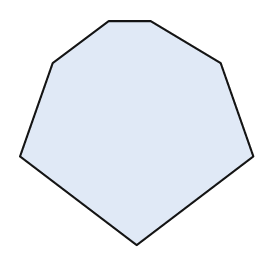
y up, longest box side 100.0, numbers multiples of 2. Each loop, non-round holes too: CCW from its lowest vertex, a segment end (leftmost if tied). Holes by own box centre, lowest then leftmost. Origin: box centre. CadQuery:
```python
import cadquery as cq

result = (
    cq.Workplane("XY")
    .moveTo(0.0, -48.0)
    .lineTo(50.0, -10.0)
    .lineTo(36.0, 30.0)
    .lineTo(6.0, 48.0)
    .lineTo(-12.0, 48.0)
    .lineTo(-36.0, 30.0)
    .lineTo(-50.0, -10.0)
    .close()
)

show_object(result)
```